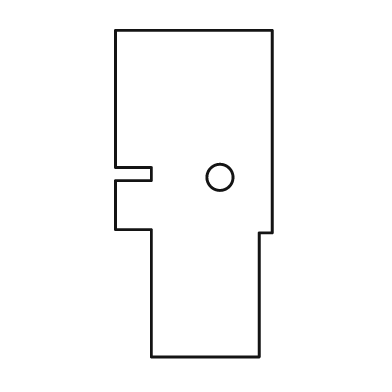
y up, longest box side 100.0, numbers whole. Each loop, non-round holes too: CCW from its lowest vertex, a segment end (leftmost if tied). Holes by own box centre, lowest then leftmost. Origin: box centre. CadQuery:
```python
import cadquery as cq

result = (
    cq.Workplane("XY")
    .moveTo(-13.0, -50.0)
    .lineTo(20.0, -50.0)
    .lineTo(20.0, -12.0)
    .lineTo(24.0, -12.0)
    .lineTo(24.0, 50.0)
    .lineTo(-24.0, 50.0)
    .lineTo(-24.0, 8.0)
    .lineTo(-13.0, 8.0)
    .lineTo(-13.0, 4.0)
    .lineTo(-24.0, 4.0)
    .lineTo(-24.0, -11.0)
    .lineTo(-13.0, -11.0)
    .close()
    .moveTo(8.0, 5.0)
    .circle(4.0)
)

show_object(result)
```